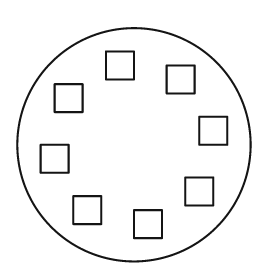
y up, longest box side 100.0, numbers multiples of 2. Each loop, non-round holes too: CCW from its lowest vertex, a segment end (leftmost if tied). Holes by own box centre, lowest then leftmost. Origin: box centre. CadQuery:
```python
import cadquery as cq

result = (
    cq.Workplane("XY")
    .moveTo(0.0, 0.0)
    .circle(50.0)
    .moveTo(0.0, -40.0)
    .lineTo(12.0, -40.0)
    .lineTo(12.0, -28.0)
    .lineTo(0.0, -28.0)
    .close()
    .moveTo(-26.0, -34.0)
    .lineTo(-14.0, -34.0)
    .lineTo(-14.0, -22.0)
    .lineTo(-26.0, -22.0)
    .close()
    .moveTo(22.0, -26.0)
    .lineTo(34.0, -26.0)
    .lineTo(34.0, -14.0)
    .lineTo(22.0, -14.0)
    .close()
    .moveTo(-40.0, -12.0)
    .lineTo(-28.0, -12.0)
    .lineTo(-28.0, 0.0)
    .lineTo(-40.0, 0.0)
    .close()
    .moveTo(28.0, 0.0)
    .lineTo(40.0, 0.0)
    .lineTo(40.0, 12.0)
    .lineTo(28.0, 12.0)
    .close()
    .moveTo(-34.0, 14.0)
    .lineTo(-22.0, 14.0)
    .lineTo(-22.0, 26.0)
    .lineTo(-34.0, 26.0)
    .close()
    .moveTo(14.0, 22.0)
    .lineTo(26.0, 22.0)
    .lineTo(26.0, 34.0)
    .lineTo(14.0, 34.0)
    .close()
    .moveTo(-12.0, 28.0)
    .lineTo(0.0, 28.0)
    .lineTo(0.0, 40.0)
    .lineTo(-12.0, 40.0)
    .close()
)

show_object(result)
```